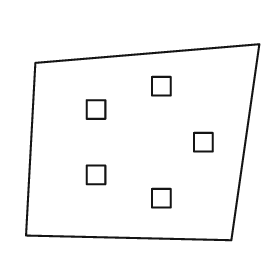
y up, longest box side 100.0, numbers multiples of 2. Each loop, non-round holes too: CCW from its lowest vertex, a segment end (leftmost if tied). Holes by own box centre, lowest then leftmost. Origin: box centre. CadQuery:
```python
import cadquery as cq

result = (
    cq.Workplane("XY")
    .moveTo(38.0, -42.0)
    .lineTo(50.0, 42.0)
    .lineTo(-46.0, 34.0)
    .lineTo(-50.0, -40.0)
    .close()
    .moveTo(4.0, -28.0)
    .lineTo(12.0, -28.0)
    .lineTo(12.0, -20.0)
    .lineTo(4.0, -20.0)
    .close()
    .moveTo(-24.0, -18.0)
    .lineTo(-16.0, -18.0)
    .lineTo(-16.0, -10.0)
    .lineTo(-24.0, -10.0)
    .close()
    .moveTo(22.0, -4.0)
    .lineTo(30.0, -4.0)
    .lineTo(30.0, 4.0)
    .lineTo(22.0, 4.0)
    .close()
    .moveTo(-24.0, 10.0)
    .lineTo(-16.0, 10.0)
    .lineTo(-16.0, 18.0)
    .lineTo(-24.0, 18.0)
    .close()
    .moveTo(4.0, 20.0)
    .lineTo(12.0, 20.0)
    .lineTo(12.0, 28.0)
    .lineTo(4.0, 28.0)
    .close()
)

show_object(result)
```